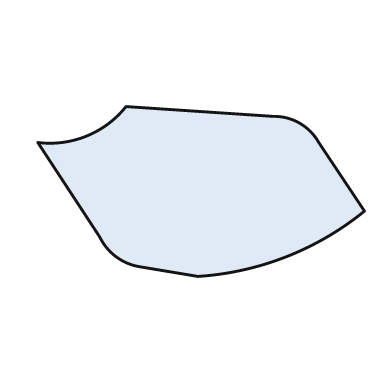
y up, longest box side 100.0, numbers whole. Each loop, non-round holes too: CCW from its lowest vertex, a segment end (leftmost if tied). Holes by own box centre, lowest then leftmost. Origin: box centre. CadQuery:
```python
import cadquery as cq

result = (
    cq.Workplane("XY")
    .moveTo(-1.0, -26.0)
    .threePointArc((26.0, -20.0), (50.0, -6.0))
    .lineTo(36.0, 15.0)
    .threePointArc((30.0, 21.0), (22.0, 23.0))
    .lineTo(-23.0, 26.0)
    .threePointArc((-35.0, 17.0), (-50.0, 15.0))
    .lineTo(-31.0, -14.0)
    .threePointArc((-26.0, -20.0), (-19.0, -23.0))
    .close()
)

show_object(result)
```